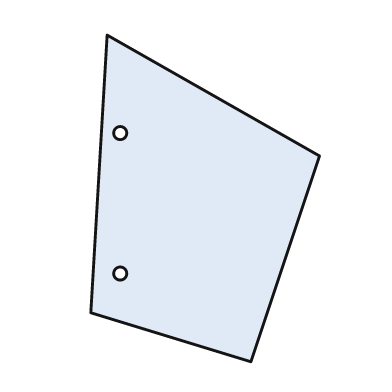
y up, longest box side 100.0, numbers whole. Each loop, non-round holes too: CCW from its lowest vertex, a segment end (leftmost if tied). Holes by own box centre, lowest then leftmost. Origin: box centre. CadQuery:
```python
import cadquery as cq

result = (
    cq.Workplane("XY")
    .moveTo(14.0, -50.0)
    .lineTo(35.0, 13.0)
    .lineTo(-30.0, 50.0)
    .lineTo(-35.0, -35.0)
    .close()
    .moveTo(-26.0, -23.0)
    .circle(2.0)
    .moveTo(-26.0, 20.0)
    .circle(2.0)
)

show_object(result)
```